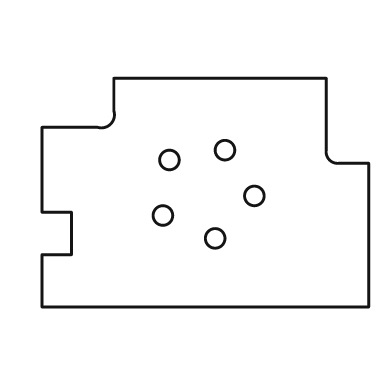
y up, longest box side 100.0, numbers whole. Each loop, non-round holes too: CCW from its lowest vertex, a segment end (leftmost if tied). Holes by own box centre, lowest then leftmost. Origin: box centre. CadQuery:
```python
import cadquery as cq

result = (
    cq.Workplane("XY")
    .moveTo(-50.0, -35.0)
    .lineTo(50.0, -35.0)
    .lineTo(50.0, 9.0)
    .lineTo(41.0, 9.0)
    .threePointArc((38.0, 10.0), (37.0, 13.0))
    .lineTo(37.0, 35.0)
    .lineTo(-28.0, 35.0)
    .lineTo(-28.0, 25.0)
    .threePointArc((-29.0, 21.0), (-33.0, 20.0))
    .lineTo(-50.0, 20.0)
    .lineTo(-50.0, -6.0)
    .lineTo(-41.0, -6.0)
    .lineTo(-41.0, -19.0)
    .lineTo(-50.0, -19.0)
    .close()
    .moveTo(3.0, -14.0)
    .circle(3.0)
    .moveTo(-13.0, -7.0)
    .circle(3.0)
    .moveTo(15.0, -1.0)
    .circle(3.0)
    .moveTo(-11.0, 10.0)
    .circle(3.0)
    .moveTo(6.0, 13.0)
    .circle(3.0)
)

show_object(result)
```